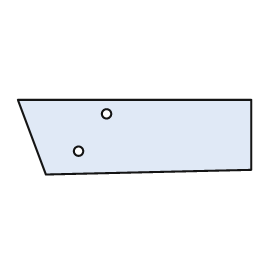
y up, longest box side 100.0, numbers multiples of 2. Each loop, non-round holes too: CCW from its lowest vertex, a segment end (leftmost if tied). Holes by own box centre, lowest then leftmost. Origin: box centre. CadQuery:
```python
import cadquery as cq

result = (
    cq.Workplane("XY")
    .moveTo(-38.0, -16.0)
    .lineTo(50.0, -14.0)
    .lineTo(50.0, 16.0)
    .lineTo(-50.0, 16.0)
    .close()
    .moveTo(-24.0, -6.0)
    .circle(2.0)
    .moveTo(-12.0, 10.0)
    .circle(2.0)
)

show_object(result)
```